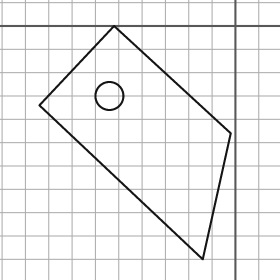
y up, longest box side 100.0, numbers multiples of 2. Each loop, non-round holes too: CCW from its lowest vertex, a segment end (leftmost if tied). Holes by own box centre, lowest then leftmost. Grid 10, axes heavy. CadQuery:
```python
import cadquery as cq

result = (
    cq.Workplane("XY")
    .moveTo(-14.0, -100.0)
    .lineTo(-2.0, -46.0)
    .lineTo(-52.0, 0.0)
    .lineTo(-84.0, -34.0)
    .close()
    .moveTo(-54.0, -30.0)
    .circle(6.0)
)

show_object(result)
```